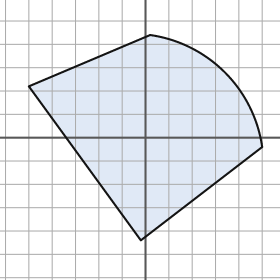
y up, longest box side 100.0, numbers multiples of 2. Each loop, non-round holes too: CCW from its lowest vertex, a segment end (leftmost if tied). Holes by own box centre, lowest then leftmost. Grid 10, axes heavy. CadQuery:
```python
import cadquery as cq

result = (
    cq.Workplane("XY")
    .moveTo(-2.0, -44.0)
    .lineTo(50.0, -4.0)
    .threePointArc((34.0, 28.0), (2.0, 44.0))
    .lineTo(-50.0, 22.0)
    .close()
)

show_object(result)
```